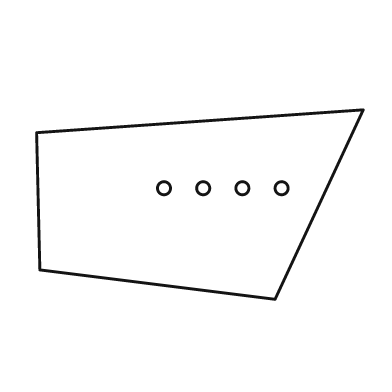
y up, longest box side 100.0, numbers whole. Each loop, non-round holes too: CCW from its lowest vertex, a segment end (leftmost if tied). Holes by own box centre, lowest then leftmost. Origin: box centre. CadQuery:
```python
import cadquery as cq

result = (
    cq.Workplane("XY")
    .moveTo(23.0, -29.0)
    .lineTo(50.0, 29.0)
    .lineTo(-50.0, 22.0)
    .lineTo(-49.0, -20.0)
    .close()
    .moveTo(-11.0, 5.0)
    .circle(2.0)
    .moveTo(1.0, 5.0)
    .circle(2.0)
    .moveTo(13.0, 5.0)
    .circle(2.0)
    .moveTo(25.0, 5.0)
    .circle(2.0)
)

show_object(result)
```